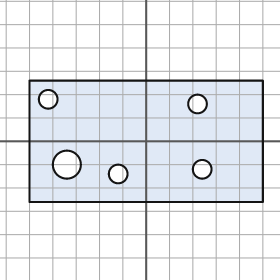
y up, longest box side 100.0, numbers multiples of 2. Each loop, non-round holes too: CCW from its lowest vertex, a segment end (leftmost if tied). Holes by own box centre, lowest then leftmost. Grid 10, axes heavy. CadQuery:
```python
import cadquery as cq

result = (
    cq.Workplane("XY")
    .moveTo(-50.0, -26.0)
    .lineTo(50.0, -26.0)
    .lineTo(50.0, 26.0)
    .lineTo(-50.0, 26.0)
    .close()
    .moveTo(-12.0, -14.0)
    .circle(4.0)
    .moveTo(24.0, -12.0)
    .circle(4.0)
    .moveTo(-34.0, -10.0)
    .circle(6.0)
    .moveTo(22.0, 16.0)
    .circle(4.0)
    .moveTo(-42.0, 18.0)
    .circle(4.0)
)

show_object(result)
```